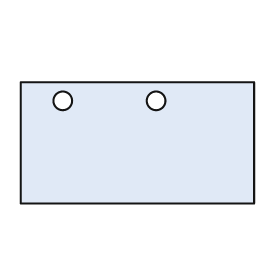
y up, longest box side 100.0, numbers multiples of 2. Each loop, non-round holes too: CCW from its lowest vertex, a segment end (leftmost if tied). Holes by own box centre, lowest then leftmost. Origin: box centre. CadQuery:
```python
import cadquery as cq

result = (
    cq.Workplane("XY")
    .moveTo(-50.0, -26.0)
    .lineTo(50.0, -26.0)
    .lineTo(50.0, 26.0)
    .lineTo(-50.0, 26.0)
    .close()
    .moveTo(-32.0, 18.0)
    .circle(4.0)
    .moveTo(8.0, 18.0)
    .circle(4.0)
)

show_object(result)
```